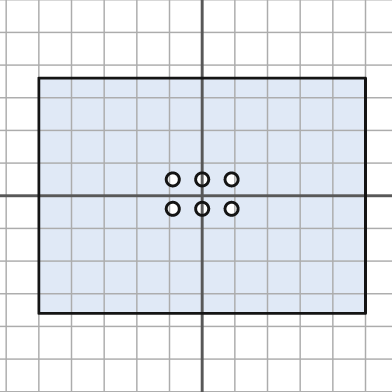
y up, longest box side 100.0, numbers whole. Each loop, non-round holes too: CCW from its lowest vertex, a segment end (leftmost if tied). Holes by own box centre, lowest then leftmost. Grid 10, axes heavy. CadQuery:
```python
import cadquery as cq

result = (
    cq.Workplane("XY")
    .moveTo(-50.0, -36.0)
    .lineTo(50.0, -36.0)
    .lineTo(50.0, 36.0)
    .lineTo(-50.0, 36.0)
    .close()
    .moveTo(-9.0, -4.0)
    .circle(2.0)
    .moveTo(0.0, -4.0)
    .circle(2.0)
    .moveTo(9.0, -4.0)
    .circle(2.0)
    .moveTo(-9.0, 5.0)
    .circle(2.0)
    .moveTo(0.0, 5.0)
    .circle(2.0)
    .moveTo(9.0, 5.0)
    .circle(2.0)
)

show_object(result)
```